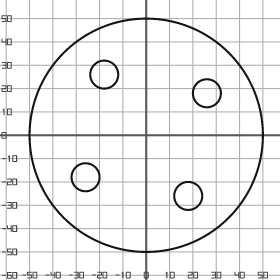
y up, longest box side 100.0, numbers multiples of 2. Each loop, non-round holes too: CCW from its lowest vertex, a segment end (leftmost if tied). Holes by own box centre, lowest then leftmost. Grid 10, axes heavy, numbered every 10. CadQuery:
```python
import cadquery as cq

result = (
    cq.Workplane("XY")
    .moveTo(0.0, 0.0)
    .circle(50.0)
    .moveTo(18.0, -26.0)
    .circle(6.0)
    .moveTo(-26.0, -18.0)
    .circle(6.0)
    .moveTo(26.0, 18.0)
    .circle(6.0)
    .moveTo(-18.0, 26.0)
    .circle(6.0)
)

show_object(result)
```